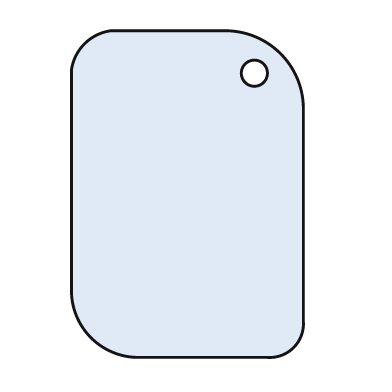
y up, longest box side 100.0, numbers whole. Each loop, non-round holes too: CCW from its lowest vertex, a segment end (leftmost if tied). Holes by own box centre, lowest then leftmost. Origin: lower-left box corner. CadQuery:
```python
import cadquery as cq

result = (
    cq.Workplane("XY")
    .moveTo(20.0, 0.0)
    .lineTo(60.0, 0.0)
    .threePointArc((68.0, 3.0), (71.0, 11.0))
    .lineTo(71.0, 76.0)
    .threePointArc((64.0, 93.0), (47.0, 100.0))
    .lineTo(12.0, 100.0)
    .threePointArc((4.0, 96.0), (0.0, 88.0))
    .lineTo(0.0, 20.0)
    .threePointArc((6.0, 6.0), (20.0, 0.0))
    .close()
    .moveTo(56.0, 87.0)
    .circle(4.0)
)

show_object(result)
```